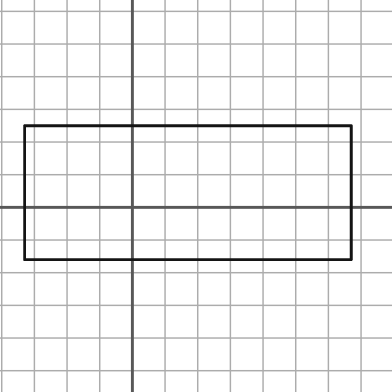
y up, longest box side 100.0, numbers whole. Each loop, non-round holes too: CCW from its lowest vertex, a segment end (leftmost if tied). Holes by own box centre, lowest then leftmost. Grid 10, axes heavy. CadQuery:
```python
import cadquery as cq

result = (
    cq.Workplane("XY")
    .moveTo(-33.0, -16.0)
    .lineTo(67.0, -16.0)
    .lineTo(67.0, 25.0)
    .lineTo(-33.0, 25.0)
    .close()
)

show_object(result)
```